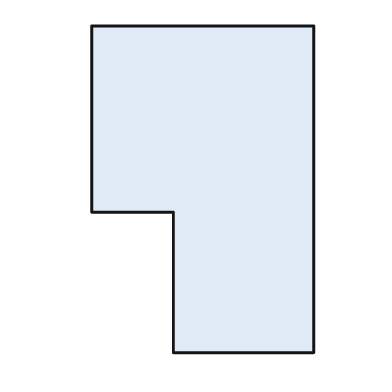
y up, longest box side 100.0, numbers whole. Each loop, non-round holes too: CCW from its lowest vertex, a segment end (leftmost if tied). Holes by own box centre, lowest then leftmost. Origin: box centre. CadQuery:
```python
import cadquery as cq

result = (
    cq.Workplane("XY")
    .moveTo(-9.0, -50.0)
    .lineTo(34.0, -50.0)
    .lineTo(34.0, 50.0)
    .lineTo(-34.0, 50.0)
    .lineTo(-34.0, -7.0)
    .lineTo(-9.0, -7.0)
    .close()
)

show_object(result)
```